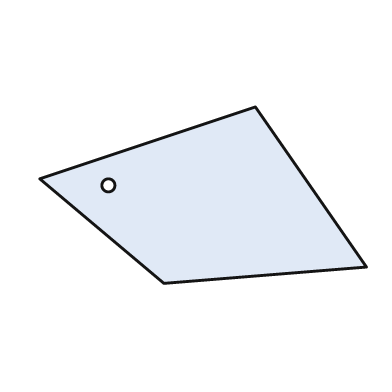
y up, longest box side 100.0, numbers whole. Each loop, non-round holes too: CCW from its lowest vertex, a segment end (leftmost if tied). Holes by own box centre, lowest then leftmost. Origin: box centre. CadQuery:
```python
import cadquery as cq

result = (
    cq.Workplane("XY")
    .moveTo(-12.0, -27.0)
    .lineTo(50.0, -22.0)
    .lineTo(16.0, 27.0)
    .lineTo(-50.0, 5.0)
    .close()
    .moveTo(-29.0, 3.0)
    .circle(2.0)
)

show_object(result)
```